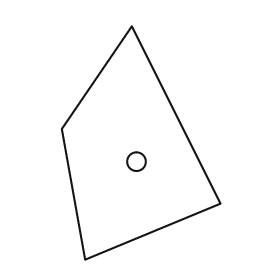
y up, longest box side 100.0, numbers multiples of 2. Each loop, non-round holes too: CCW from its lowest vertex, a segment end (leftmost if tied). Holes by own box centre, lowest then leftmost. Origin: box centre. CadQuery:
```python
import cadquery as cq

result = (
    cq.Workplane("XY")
    .moveTo(-24.0, -50.0)
    .lineTo(34.0, -26.0)
    .lineTo(-4.0, 50.0)
    .lineTo(-34.0, 6.0)
    .close()
    .moveTo(-2.0, -8.0)
    .circle(4.0)
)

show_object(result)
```